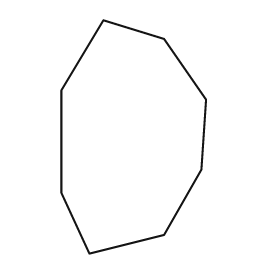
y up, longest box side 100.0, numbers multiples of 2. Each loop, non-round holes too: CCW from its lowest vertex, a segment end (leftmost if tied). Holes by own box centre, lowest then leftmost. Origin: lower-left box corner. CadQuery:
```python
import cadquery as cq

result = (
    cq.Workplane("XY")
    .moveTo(12.0, 0.0)
    .lineTo(44.0, 8.0)
    .lineTo(60.0, 36.0)
    .lineTo(62.0, 66.0)
    .lineTo(44.0, 92.0)
    .lineTo(18.0, 100.0)
    .lineTo(0.0, 70.0)
    .lineTo(0.0, 26.0)
    .close()
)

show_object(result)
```